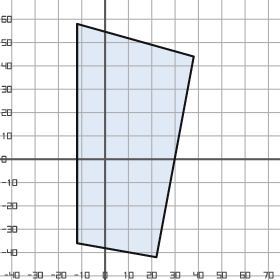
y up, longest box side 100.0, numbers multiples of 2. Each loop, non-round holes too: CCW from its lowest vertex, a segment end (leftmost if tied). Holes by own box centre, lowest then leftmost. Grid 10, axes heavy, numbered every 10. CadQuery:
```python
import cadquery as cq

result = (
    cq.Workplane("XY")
    .moveTo(22.0, -42.0)
    .lineTo(38.0, 44.0)
    .lineTo(-12.0, 58.0)
    .lineTo(-12.0, -36.0)
    .close()
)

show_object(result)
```